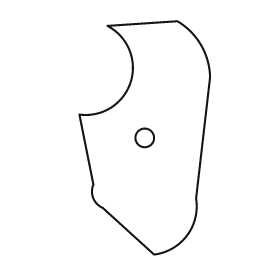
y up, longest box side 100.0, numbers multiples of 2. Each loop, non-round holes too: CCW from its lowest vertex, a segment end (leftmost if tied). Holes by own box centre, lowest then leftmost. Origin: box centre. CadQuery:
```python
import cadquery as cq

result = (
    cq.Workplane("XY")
    .moveTo(4.0, -50.0)
    .threePointArc((18.0, -42.0), (22.0, -26.0))
    .lineTo(28.0, 26.0)
    .threePointArc((24.0, 40.0), (14.0, 50.0))
    .lineTo(-16.0, 48.0)
    .threePointArc((-6.0, 24.0), (-28.0, 10.0))
    .lineTo(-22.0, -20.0)
    .threePointArc((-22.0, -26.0), (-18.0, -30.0))
    .close()
    .moveTo(0.0, 0.0)
    .circle(4.0)
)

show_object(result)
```